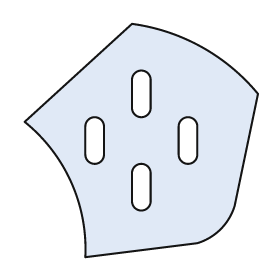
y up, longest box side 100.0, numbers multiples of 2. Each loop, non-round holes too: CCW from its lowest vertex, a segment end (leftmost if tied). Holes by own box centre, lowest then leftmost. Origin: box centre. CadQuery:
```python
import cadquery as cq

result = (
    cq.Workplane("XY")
    .moveTo(-24.0, -50.0)
    .lineTo(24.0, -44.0)
    .threePointArc((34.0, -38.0), (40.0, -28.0))
    .lineTo(50.0, 20.0)
    .threePointArc((26.0, 40.0), (-4.0, 50.0))
    .lineTo(-50.0, 8.0)
    .threePointArc((-30.0, -18.0), (-24.0, -50.0))
    .close()
    .moveTo(-4.0, -26.0)
    .threePointArc((0.0, -30.0), (4.0, -26.0))
    .lineTo(4.0, -14.0)
    .threePointArc((0.0, -10.0), (-4.0, -14.0))
    .close()
    .moveTo(-24.0, -6.0)
    .threePointArc((-20.0, -10.0), (-16.0, -6.0))
    .lineTo(-16.0, 6.0)
    .threePointArc((-20.0, 10.0), (-24.0, 6.0))
    .close()
    .moveTo(16.0, -6.0)
    .threePointArc((20.0, -10.0), (24.0, -6.0))
    .lineTo(24.0, 6.0)
    .threePointArc((20.0, 10.0), (16.0, 6.0))
    .close()
    .moveTo(-4.0, 14.0)
    .threePointArc((0.0, 10.0), (4.0, 14.0))
    .lineTo(4.0, 26.0)
    .threePointArc((0.0, 30.0), (-4.0, 26.0))
    .close()
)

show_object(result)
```